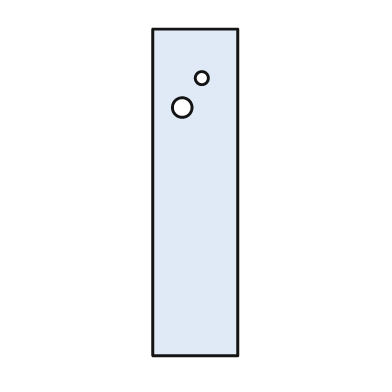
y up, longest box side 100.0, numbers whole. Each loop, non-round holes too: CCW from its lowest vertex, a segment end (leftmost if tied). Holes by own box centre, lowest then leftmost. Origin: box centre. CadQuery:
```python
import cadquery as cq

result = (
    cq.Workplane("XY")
    .moveTo(-13.0, -50.0)
    .lineTo(13.0, -50.0)
    .lineTo(13.0, 50.0)
    .lineTo(-13.0, 50.0)
    .close()
    .moveTo(-4.0, 26.0)
    .circle(3.0)
    .moveTo(2.0, 35.0)
    .circle(2.0)
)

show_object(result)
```